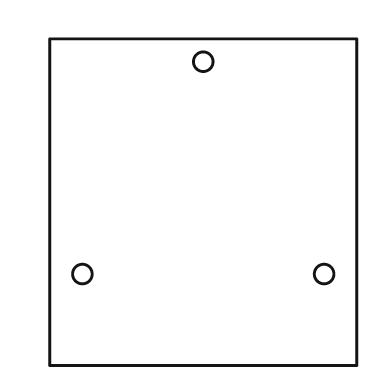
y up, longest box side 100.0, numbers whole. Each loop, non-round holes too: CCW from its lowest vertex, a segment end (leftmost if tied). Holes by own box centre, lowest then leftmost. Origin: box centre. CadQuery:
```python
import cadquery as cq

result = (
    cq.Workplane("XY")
    .moveTo(-47.0, -50.0)
    .lineTo(47.0, -50.0)
    .lineTo(47.0, 50.0)
    .lineTo(-47.0, 50.0)
    .close()
    .moveTo(-37.0, -22.0)
    .circle(3.0)
    .moveTo(37.0, -22.0)
    .circle(3.0)
    .moveTo(0.0, 43.0)
    .circle(3.0)
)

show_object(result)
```